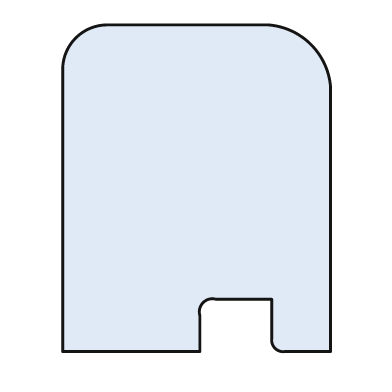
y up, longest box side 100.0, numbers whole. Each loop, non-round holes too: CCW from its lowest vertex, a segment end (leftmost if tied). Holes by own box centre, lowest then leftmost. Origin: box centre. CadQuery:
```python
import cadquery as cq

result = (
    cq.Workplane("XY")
    .moveTo(-41.0, -50.0)
    .lineTo(1.0, -50.0)
    .lineTo(1.0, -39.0)
    .threePointArc((2.0, -35.0), (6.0, -34.0))
    .lineTo(23.0, -34.0)
    .lineTo(23.0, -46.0)
    .threePointArc((24.0, -49.0), (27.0, -50.0))
    .lineTo(41.0, -50.0)
    .lineTo(41.0, 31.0)
    .threePointArc((35.0, 44.0), (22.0, 50.0))
    .lineTo(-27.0, 50.0)
    .threePointArc((-37.0, 46.0), (-41.0, 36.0))
    .close()
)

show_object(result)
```